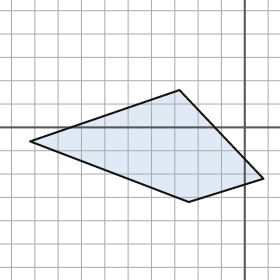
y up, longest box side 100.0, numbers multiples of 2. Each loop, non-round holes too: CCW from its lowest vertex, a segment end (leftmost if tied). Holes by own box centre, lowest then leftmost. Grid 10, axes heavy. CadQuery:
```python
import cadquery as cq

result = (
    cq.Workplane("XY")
    .moveTo(-24.0, -32.0)
    .lineTo(8.0, -22.0)
    .lineTo(-28.0, 16.0)
    .lineTo(-92.0, -6.0)
    .close()
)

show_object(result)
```